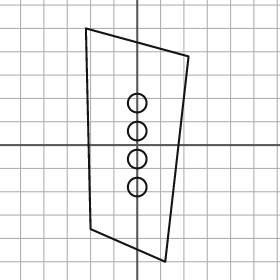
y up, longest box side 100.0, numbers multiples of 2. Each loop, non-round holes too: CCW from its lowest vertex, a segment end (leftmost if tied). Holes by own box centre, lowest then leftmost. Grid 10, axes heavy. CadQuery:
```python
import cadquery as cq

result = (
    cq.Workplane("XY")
    .moveTo(12.0, -50.0)
    .lineTo(22.0, 38.0)
    .lineTo(-22.0, 50.0)
    .lineTo(-20.0, -36.0)
    .close()
    .moveTo(0.0, -18.0)
    .circle(4.0)
    .moveTo(0.0, -6.0)
    .circle(4.0)
    .moveTo(0.0, 6.0)
    .circle(4.0)
    .moveTo(0.0, 18.0)
    .circle(4.0)
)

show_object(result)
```